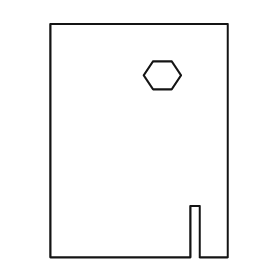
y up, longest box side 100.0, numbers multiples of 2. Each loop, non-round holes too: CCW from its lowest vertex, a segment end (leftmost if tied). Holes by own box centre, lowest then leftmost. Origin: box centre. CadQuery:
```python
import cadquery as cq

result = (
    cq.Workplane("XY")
    .moveTo(-38.0, -50.0)
    .lineTo(22.0, -50.0)
    .lineTo(22.0, -28.0)
    .lineTo(26.0, -28.0)
    .lineTo(26.0, -50.0)
    .lineTo(38.0, -50.0)
    .lineTo(38.0, 50.0)
    .lineTo(-38.0, 50.0)
    .close()
    .moveTo(6.0, 22.0)
    .lineTo(14.0, 22.0)
    .lineTo(18.0, 28.0)
    .lineTo(14.0, 34.0)
    .lineTo(6.0, 34.0)
    .lineTo(2.0, 28.0)
    .close()
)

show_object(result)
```